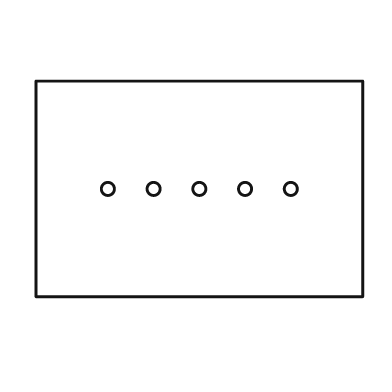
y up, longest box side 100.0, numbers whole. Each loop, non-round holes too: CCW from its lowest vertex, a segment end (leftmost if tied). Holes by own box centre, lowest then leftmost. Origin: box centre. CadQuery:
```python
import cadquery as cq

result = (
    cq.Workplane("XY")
    .moveTo(-50.0, -33.0)
    .lineTo(50.0, -33.0)
    .lineTo(50.0, 33.0)
    .lineTo(-50.0, 33.0)
    .close()
    .moveTo(-28.0, 0.0)
    .circle(2.0)
    .moveTo(-14.0, 0.0)
    .circle(2.0)
    .moveTo(0.0, 0.0)
    .circle(2.0)
    .moveTo(14.0, 0.0)
    .circle(2.0)
    .moveTo(28.0, 0.0)
    .circle(2.0)
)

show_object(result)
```